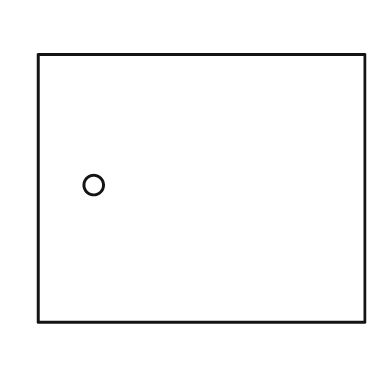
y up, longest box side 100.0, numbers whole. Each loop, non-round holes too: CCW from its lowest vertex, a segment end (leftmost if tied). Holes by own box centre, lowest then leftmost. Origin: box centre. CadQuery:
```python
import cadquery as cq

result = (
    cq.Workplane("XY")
    .moveTo(-50.0, -41.0)
    .lineTo(50.0, -41.0)
    .lineTo(50.0, 41.0)
    .lineTo(-50.0, 41.0)
    .close()
    .moveTo(-33.0, 1.0)
    .circle(3.0)
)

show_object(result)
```